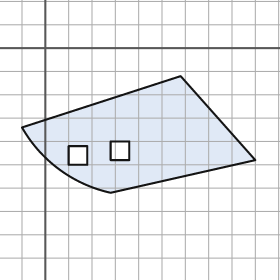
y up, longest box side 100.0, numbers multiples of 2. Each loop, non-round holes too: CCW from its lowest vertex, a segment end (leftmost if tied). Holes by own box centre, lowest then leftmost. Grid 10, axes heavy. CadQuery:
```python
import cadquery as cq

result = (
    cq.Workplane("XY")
    .moveTo(28.0, -62.0)
    .lineTo(90.0, -48.0)
    .lineTo(58.0, -12.0)
    .lineTo(-10.0, -34.0)
    .threePointArc((6.0, -52.0), (28.0, -62.0))
    .close()
    .moveTo(10.0, -50.0)
    .lineTo(18.0, -50.0)
    .lineTo(18.0, -42.0)
    .lineTo(10.0, -42.0)
    .close()
    .moveTo(28.0, -48.0)
    .lineTo(36.0, -48.0)
    .lineTo(36.0, -40.0)
    .lineTo(28.0, -40.0)
    .close()
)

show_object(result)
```